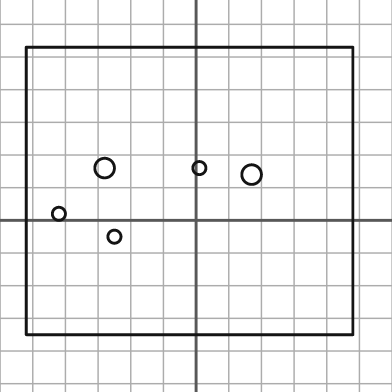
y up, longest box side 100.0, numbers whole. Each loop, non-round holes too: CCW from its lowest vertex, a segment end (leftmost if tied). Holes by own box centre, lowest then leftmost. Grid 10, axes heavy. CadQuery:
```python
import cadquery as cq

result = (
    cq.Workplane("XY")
    .moveTo(-52.0, -35.0)
    .lineTo(48.0, -35.0)
    .lineTo(48.0, 53.0)
    .lineTo(-52.0, 53.0)
    .close()
    .moveTo(-25.0, -5.0)
    .circle(2.0)
    .moveTo(-42.0, 2.0)
    .circle(2.0)
    .moveTo(17.0, 14.0)
    .circle(3.0)
    .moveTo(-28.0, 16.0)
    .circle(3.0)
    .moveTo(1.0, 16.0)
    .circle(2.0)
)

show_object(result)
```